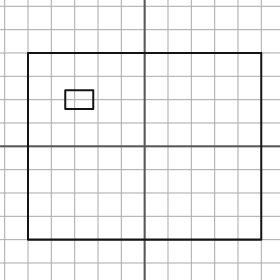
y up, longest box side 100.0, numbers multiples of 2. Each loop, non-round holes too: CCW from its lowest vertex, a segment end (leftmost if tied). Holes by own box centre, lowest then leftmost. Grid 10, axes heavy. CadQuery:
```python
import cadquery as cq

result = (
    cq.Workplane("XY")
    .moveTo(-50.0, -40.0)
    .lineTo(50.0, -40.0)
    .lineTo(50.0, 40.0)
    .lineTo(-50.0, 40.0)
    .close()
    .moveTo(-34.0, 16.0)
    .lineTo(-22.0, 16.0)
    .lineTo(-22.0, 24.0)
    .lineTo(-34.0, 24.0)
    .close()
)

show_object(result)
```